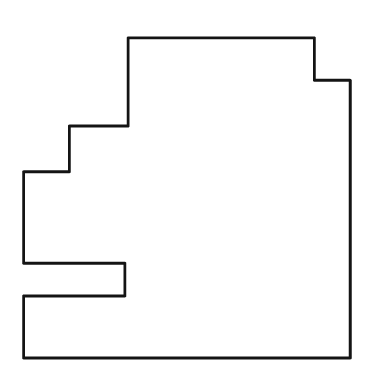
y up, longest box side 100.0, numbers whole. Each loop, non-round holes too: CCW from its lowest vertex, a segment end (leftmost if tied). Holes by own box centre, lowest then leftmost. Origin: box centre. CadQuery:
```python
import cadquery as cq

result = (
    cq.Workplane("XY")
    .moveTo(-50.0, -49.0)
    .lineTo(50.0, -49.0)
    .lineTo(50.0, 36.0)
    .lineTo(39.0, 36.0)
    .lineTo(39.0, 49.0)
    .lineTo(-18.0, 49.0)
    .lineTo(-18.0, 22.0)
    .lineTo(-36.0, 22.0)
    .lineTo(-36.0, 8.0)
    .lineTo(-50.0, 8.0)
    .lineTo(-50.0, -20.0)
    .lineTo(-19.0, -20.0)
    .lineTo(-19.0, -30.0)
    .lineTo(-50.0, -30.0)
    .close()
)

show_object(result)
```